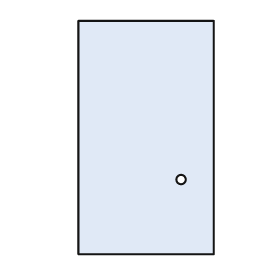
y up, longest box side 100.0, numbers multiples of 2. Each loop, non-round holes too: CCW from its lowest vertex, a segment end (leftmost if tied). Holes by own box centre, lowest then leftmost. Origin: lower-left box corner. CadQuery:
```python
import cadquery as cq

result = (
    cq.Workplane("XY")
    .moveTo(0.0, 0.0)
    .lineTo(58.0, 0.0)
    .lineTo(58.0, 100.0)
    .lineTo(0.0, 100.0)
    .close()
    .moveTo(44.0, 32.0)
    .circle(2.0)
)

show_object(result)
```